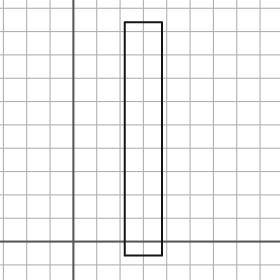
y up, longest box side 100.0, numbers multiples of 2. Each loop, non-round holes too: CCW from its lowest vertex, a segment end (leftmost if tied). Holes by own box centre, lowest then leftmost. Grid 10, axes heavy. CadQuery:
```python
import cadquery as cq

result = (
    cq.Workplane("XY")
    .moveTo(22.0, -6.0)
    .lineTo(38.0, -6.0)
    .lineTo(38.0, 94.0)
    .lineTo(22.0, 94.0)
    .close()
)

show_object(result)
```